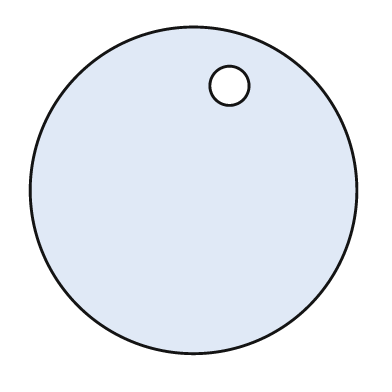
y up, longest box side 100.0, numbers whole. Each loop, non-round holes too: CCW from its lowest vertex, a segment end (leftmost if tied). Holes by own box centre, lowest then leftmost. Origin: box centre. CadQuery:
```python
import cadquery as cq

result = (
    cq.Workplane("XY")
    .moveTo(0.0, 0.0)
    .circle(50.0)
    .moveTo(11.0, 32.0)
    .circle(6.0)
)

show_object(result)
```